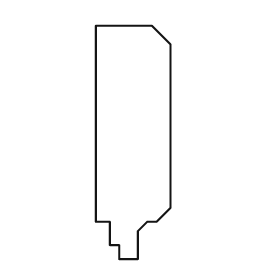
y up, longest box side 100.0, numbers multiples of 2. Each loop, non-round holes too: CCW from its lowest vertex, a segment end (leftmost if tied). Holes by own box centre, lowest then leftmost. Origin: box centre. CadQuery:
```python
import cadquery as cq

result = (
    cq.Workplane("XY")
    .moveTo(-6.0, -50.0)
    .lineTo(2.0, -50.0)
    .lineTo(2.0, -38.0)
    .lineTo(6.0, -34.0)
    .lineTo(10.0, -34.0)
    .lineTo(16.0, -28.0)
    .lineTo(16.0, 42.0)
    .lineTo(8.0, 50.0)
    .lineTo(-16.0, 50.0)
    .lineTo(-16.0, -34.0)
    .lineTo(-10.0, -34.0)
    .lineTo(-10.0, -44.0)
    .lineTo(-6.0, -44.0)
    .close()
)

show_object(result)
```